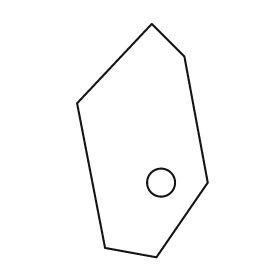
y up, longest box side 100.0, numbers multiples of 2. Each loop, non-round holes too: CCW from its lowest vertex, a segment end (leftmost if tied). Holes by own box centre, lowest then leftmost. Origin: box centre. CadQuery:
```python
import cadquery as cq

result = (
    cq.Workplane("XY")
    .moveTo(6.0, -50.0)
    .lineTo(28.0, -18.0)
    .lineTo(18.0, 36.0)
    .lineTo(4.0, 50.0)
    .lineTo(-28.0, 16.0)
    .lineTo(-16.0, -46.0)
    .close()
    .moveTo(8.0, -18.0)
    .circle(6.0)
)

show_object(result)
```